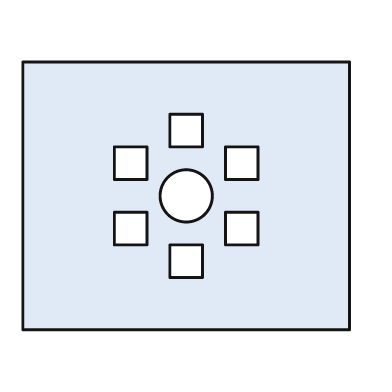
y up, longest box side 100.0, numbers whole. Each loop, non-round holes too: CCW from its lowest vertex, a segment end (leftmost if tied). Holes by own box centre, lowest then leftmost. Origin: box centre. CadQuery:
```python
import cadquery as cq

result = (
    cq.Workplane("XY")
    .moveTo(-50.0, -41.0)
    .lineTo(50.0, -41.0)
    .lineTo(50.0, 41.0)
    .lineTo(-50.0, 41.0)
    .close()
    .moveTo(-5.0, -25.0)
    .lineTo(5.0, -25.0)
    .lineTo(5.0, -15.0)
    .lineTo(-5.0, -15.0)
    .close()
    .moveTo(-22.0, -15.0)
    .lineTo(-12.0, -15.0)
    .lineTo(-12.0, -5.0)
    .lineTo(-22.0, -5.0)
    .close()
    .moveTo(12.0, -15.0)
    .lineTo(22.0, -15.0)
    .lineTo(22.0, -5.0)
    .lineTo(12.0, -5.0)
    .close()
    .moveTo(0.0, 0.0)
    .circle(8.0)
    .moveTo(-22.0, 5.0)
    .lineTo(-12.0, 5.0)
    .lineTo(-12.0, 15.0)
    .lineTo(-22.0, 15.0)
    .close()
    .moveTo(12.0, 5.0)
    .lineTo(22.0, 5.0)
    .lineTo(22.0, 15.0)
    .lineTo(12.0, 15.0)
    .close()
    .moveTo(-5.0, 15.0)
    .lineTo(5.0, 15.0)
    .lineTo(5.0, 25.0)
    .lineTo(-5.0, 25.0)
    .close()
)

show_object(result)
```